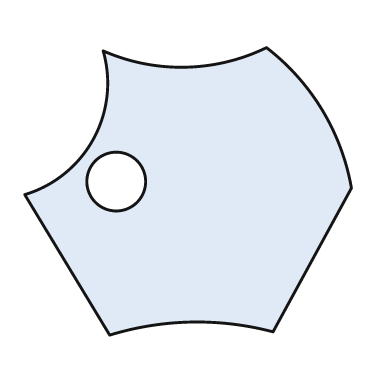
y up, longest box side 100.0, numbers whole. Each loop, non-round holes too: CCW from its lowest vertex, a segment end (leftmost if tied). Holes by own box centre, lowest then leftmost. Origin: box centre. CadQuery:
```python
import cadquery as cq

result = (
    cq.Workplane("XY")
    .moveTo(-24.0, -44.0)
    .threePointArc((1.0, -40.0), (26.0, -43.0))
    .lineTo(50.0, 1.0)
    .threePointArc((41.0, 25.0), (24.0, 44.0))
    .threePointArc((-1.0, 38.0), (-26.0, 43.0))
    .threePointArc((-29.0, 16.0), (-50.0, -1.0))
    .close()
    .moveTo(-22.0, 3.0)
    .circle(9.0)
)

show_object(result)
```